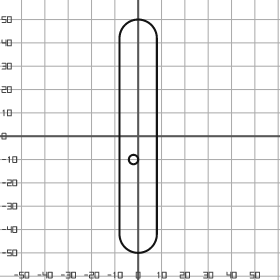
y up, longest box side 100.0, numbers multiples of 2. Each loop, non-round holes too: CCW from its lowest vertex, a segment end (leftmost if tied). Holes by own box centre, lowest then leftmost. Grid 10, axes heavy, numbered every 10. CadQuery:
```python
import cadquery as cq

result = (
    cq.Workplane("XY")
    .moveTo(-8.0, -42.0)
    .threePointArc((0.0, -50.0), (8.0, -42.0))
    .lineTo(8.0, 42.0)
    .threePointArc((0.0, 50.0), (-8.0, 42.0))
    .close()
    .moveTo(-2.0, -10.0)
    .circle(2.0)
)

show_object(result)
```